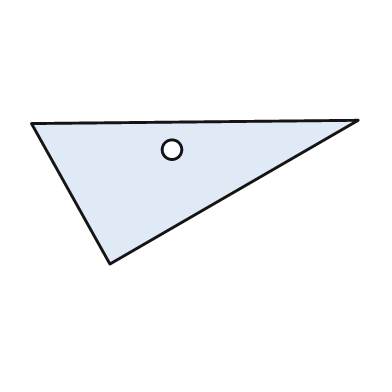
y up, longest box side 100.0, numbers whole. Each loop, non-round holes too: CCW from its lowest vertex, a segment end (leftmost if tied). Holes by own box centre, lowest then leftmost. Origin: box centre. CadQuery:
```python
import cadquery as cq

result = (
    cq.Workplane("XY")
    .moveTo(-26.0, -22.0)
    .lineTo(50.0, 22.0)
    .lineTo(-50.0, 21.0)
    .close()
    .moveTo(-7.0, 13.0)
    .circle(3.0)
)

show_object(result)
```